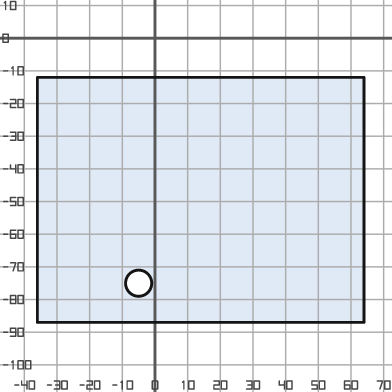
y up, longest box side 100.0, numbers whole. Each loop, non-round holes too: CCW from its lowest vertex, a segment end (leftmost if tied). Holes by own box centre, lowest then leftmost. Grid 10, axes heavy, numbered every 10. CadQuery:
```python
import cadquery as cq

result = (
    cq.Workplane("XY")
    .moveTo(-36.0, -87.0)
    .lineTo(64.0, -87.0)
    .lineTo(64.0, -12.0)
    .lineTo(-36.0, -12.0)
    .close()
    .moveTo(-5.0, -75.0)
    .circle(4.0)
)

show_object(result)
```